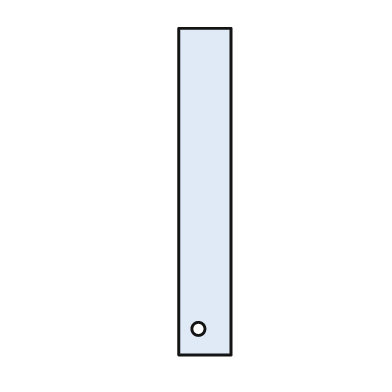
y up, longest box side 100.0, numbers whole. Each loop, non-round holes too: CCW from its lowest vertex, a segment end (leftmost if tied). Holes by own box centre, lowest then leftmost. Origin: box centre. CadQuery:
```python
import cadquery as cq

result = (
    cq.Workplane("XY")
    .moveTo(-8.0, -50.0)
    .lineTo(8.0, -50.0)
    .lineTo(8.0, 50.0)
    .lineTo(-8.0, 50.0)
    .close()
    .moveTo(-2.0, -42.0)
    .circle(2.0)
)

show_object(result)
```